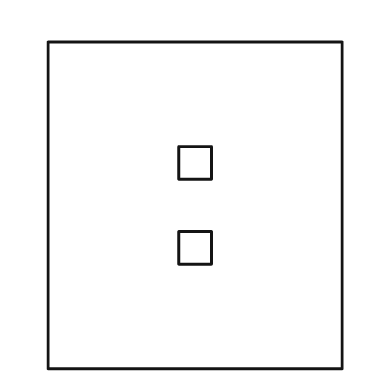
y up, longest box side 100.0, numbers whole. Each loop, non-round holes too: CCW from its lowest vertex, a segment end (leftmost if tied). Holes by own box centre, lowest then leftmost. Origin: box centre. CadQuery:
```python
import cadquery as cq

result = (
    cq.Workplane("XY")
    .moveTo(-45.0, -50.0)
    .lineTo(45.0, -50.0)
    .lineTo(45.0, 50.0)
    .lineTo(-45.0, 50.0)
    .close()
    .moveTo(-5.0, -18.0)
    .lineTo(5.0, -18.0)
    .lineTo(5.0, -8.0)
    .lineTo(-5.0, -8.0)
    .close()
    .moveTo(-5.0, 8.0)
    .lineTo(5.0, 8.0)
    .lineTo(5.0, 18.0)
    .lineTo(-5.0, 18.0)
    .close()
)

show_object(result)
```